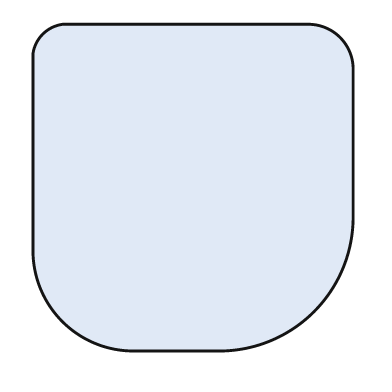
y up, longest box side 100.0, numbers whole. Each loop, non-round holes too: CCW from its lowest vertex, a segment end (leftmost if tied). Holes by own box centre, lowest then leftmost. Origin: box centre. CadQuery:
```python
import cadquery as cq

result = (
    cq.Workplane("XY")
    .moveTo(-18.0, -50.0)
    .lineTo(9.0, -50.0)
    .threePointArc((37.0, -38.0), (49.0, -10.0))
    .lineTo(49.0, 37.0)
    .threePointArc((45.0, 46.0), (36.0, 50.0))
    .lineTo(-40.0, 50.0)
    .threePointArc((-46.0, 47.0), (-49.0, 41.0))
    .lineTo(-49.0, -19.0)
    .threePointArc((-40.0, -41.0), (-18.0, -50.0))
    .close()
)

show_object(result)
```